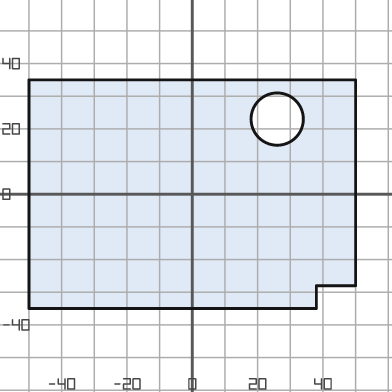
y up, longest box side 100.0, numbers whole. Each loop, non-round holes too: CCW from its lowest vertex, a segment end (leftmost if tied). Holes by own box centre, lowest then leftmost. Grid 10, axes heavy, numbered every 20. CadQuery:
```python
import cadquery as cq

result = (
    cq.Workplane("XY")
    .moveTo(-50.0, -35.0)
    .lineTo(38.0, -35.0)
    .lineTo(38.0, -28.0)
    .lineTo(50.0, -28.0)
    .lineTo(50.0, 35.0)
    .lineTo(-50.0, 35.0)
    .close()
    .moveTo(26.0, 23.0)
    .circle(8.0)
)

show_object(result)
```